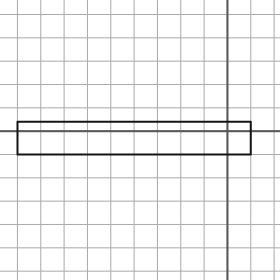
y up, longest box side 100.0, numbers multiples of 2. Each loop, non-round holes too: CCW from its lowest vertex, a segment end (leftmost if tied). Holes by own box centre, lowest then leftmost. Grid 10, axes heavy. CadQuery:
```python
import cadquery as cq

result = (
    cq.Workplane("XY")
    .moveTo(-90.0, -10.0)
    .lineTo(10.0, -10.0)
    .lineTo(10.0, 4.0)
    .lineTo(-90.0, 4.0)
    .close()
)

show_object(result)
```